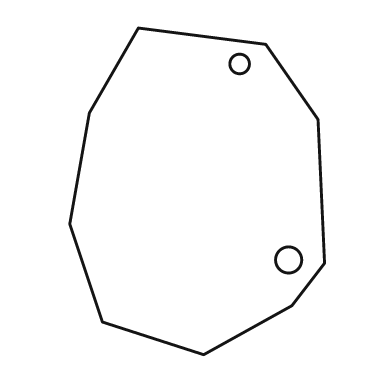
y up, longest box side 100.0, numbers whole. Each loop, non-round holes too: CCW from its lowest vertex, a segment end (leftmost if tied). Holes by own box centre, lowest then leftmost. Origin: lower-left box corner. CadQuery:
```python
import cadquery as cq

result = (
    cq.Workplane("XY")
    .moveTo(41.0, 0.0)
    .lineTo(68.0, 15.0)
    .lineTo(78.0, 28.0)
    .lineTo(76.0, 72.0)
    .lineTo(60.0, 95.0)
    .lineTo(21.0, 100.0)
    .lineTo(6.0, 74.0)
    .lineTo(0.0, 40.0)
    .lineTo(10.0, 10.0)
    .close()
    .moveTo(67.0, 29.0)
    .circle(4.0)
    .moveTo(52.0, 89.0)
    .circle(3.0)
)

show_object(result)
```